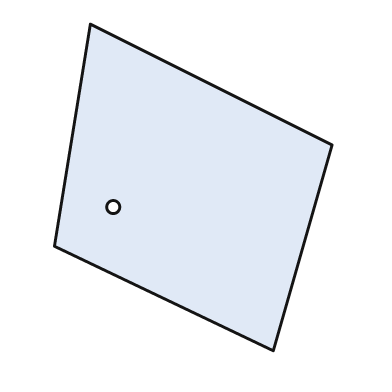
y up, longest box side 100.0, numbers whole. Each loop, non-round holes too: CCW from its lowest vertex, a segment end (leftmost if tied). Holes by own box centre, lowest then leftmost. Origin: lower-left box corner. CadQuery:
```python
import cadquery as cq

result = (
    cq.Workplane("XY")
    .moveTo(67.0, 0.0)
    .lineTo(85.0, 63.0)
    .lineTo(11.0, 100.0)
    .lineTo(0.0, 32.0)
    .close()
    .moveTo(18.0, 44.0)
    .circle(2.0)
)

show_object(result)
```